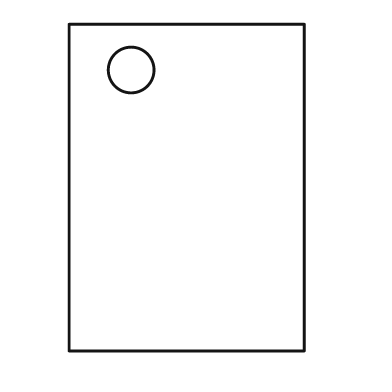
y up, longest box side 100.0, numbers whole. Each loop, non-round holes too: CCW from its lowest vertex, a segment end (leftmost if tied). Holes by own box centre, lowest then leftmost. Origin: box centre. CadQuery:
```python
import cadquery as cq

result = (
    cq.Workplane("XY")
    .moveTo(-36.0, -50.0)
    .lineTo(36.0, -50.0)
    .lineTo(36.0, 50.0)
    .lineTo(-36.0, 50.0)
    .close()
    .moveTo(-17.0, 36.0)
    .circle(7.0)
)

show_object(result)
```